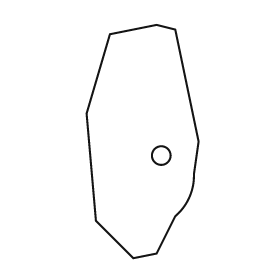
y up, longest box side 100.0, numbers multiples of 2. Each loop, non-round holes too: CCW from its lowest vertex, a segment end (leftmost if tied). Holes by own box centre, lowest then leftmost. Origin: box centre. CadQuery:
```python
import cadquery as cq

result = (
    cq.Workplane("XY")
    .moveTo(-4.0, -50.0)
    .lineTo(6.0, -48.0)
    .lineTo(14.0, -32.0)
    .threePointArc((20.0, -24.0), (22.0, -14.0))
    .lineTo(24.0, 0.0)
    .lineTo(14.0, 48.0)
    .lineTo(6.0, 50.0)
    .lineTo(-14.0, 46.0)
    .lineTo(-24.0, 12.0)
    .lineTo(-20.0, -34.0)
    .close()
    .moveTo(8.0, -6.0)
    .circle(4.0)
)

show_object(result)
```